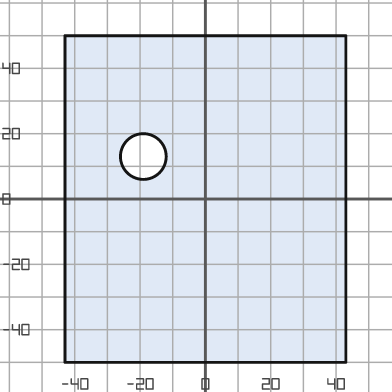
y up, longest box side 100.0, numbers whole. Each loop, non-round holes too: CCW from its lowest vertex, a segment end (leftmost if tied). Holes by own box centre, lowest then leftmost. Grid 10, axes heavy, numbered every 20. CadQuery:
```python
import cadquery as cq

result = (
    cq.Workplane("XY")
    .moveTo(-43.0, -50.0)
    .lineTo(43.0, -50.0)
    .lineTo(43.0, 50.0)
    .lineTo(-43.0, 50.0)
    .close()
    .moveTo(-19.0, 13.0)
    .circle(7.0)
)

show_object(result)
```